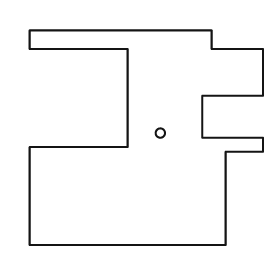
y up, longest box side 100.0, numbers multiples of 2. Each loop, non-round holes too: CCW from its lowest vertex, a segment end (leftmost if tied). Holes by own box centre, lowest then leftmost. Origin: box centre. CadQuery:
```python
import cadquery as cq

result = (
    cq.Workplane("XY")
    .moveTo(-50.0, -46.0)
    .lineTo(34.0, -46.0)
    .lineTo(34.0, -6.0)
    .lineTo(50.0, -6.0)
    .lineTo(50.0, 0.0)
    .lineTo(24.0, 0.0)
    .lineTo(24.0, 18.0)
    .lineTo(50.0, 18.0)
    .lineTo(50.0, 38.0)
    .lineTo(28.0, 38.0)
    .lineTo(28.0, 46.0)
    .lineTo(-50.0, 46.0)
    .lineTo(-50.0, 38.0)
    .lineTo(-8.0, 38.0)
    .lineTo(-8.0, -4.0)
    .lineTo(-50.0, -4.0)
    .close()
    .moveTo(6.0, 2.0)
    .circle(2.0)
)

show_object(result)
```